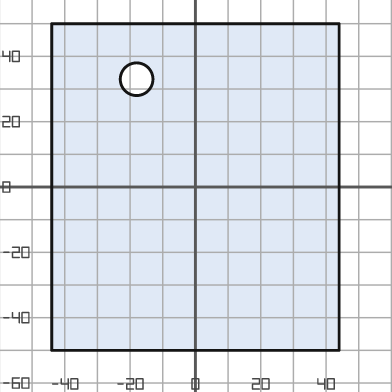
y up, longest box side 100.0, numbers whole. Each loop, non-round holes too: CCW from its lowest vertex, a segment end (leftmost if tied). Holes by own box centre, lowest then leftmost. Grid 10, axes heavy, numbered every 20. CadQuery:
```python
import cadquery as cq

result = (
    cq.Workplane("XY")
    .moveTo(-44.0, -50.0)
    .lineTo(44.0, -50.0)
    .lineTo(44.0, 50.0)
    .lineTo(-44.0, 50.0)
    .close()
    .moveTo(-18.0, 33.0)
    .circle(5.0)
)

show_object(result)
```